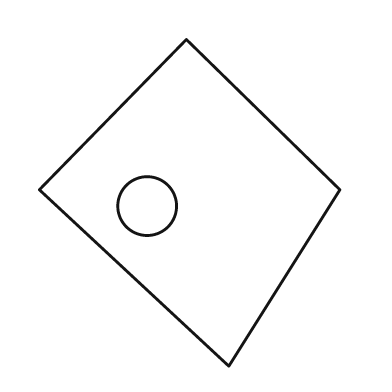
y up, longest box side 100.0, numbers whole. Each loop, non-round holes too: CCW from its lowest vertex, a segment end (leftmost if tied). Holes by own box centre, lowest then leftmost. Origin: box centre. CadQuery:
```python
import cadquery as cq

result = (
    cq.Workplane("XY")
    .moveTo(12.0, -50.0)
    .lineTo(46.0, 4.0)
    .lineTo(-1.0, 50.0)
    .lineTo(-46.0, 4.0)
    .close()
    .moveTo(-13.0, -1.0)
    .circle(9.0)
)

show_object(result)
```